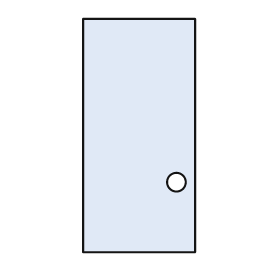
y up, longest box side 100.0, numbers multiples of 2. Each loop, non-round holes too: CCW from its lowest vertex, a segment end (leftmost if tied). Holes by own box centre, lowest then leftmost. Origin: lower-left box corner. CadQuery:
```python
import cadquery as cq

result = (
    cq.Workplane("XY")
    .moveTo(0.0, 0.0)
    .lineTo(48.0, 0.0)
    .lineTo(48.0, 100.0)
    .lineTo(0.0, 100.0)
    .close()
    .moveTo(40.0, 30.0)
    .circle(4.0)
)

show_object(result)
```